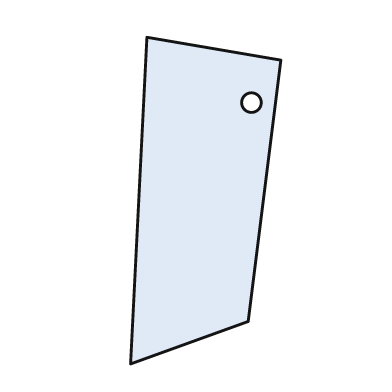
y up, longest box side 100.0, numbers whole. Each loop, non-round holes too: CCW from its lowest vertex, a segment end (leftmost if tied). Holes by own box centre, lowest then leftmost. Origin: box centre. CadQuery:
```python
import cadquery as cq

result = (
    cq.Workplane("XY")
    .moveTo(-23.0, -50.0)
    .lineTo(13.0, -37.0)
    .lineTo(23.0, 43.0)
    .lineTo(-18.0, 50.0)
    .close()
    .moveTo(14.0, 30.0)
    .circle(3.0)
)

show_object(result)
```